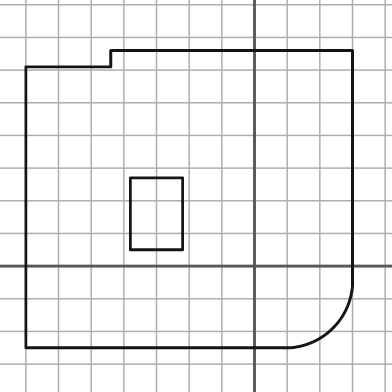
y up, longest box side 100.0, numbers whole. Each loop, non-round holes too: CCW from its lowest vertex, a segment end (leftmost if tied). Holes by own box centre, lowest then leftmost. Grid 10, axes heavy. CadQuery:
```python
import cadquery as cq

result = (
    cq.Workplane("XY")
    .moveTo(-70.0, -25.0)
    .lineTo(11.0, -25.0)
    .threePointArc((24.0, -19.0), (30.0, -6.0))
    .lineTo(30.0, 66.0)
    .lineTo(-44.0, 66.0)
    .lineTo(-44.0, 61.0)
    .lineTo(-70.0, 61.0)
    .close()
    .moveTo(-38.0, 5.0)
    .lineTo(-22.0, 5.0)
    .lineTo(-22.0, 27.0)
    .lineTo(-38.0, 27.0)
    .close()
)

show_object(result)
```